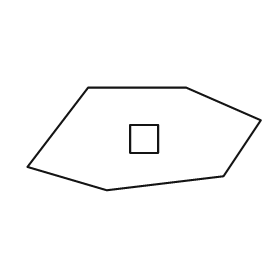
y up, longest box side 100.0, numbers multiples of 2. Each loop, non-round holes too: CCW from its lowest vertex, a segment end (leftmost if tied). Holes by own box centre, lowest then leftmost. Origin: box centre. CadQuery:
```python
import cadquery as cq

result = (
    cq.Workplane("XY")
    .moveTo(-16.0, -22.0)
    .lineTo(34.0, -16.0)
    .lineTo(50.0, 8.0)
    .lineTo(18.0, 22.0)
    .lineTo(-24.0, 22.0)
    .lineTo(-50.0, -12.0)
    .close()
    .moveTo(-6.0, -6.0)
    .lineTo(6.0, -6.0)
    .lineTo(6.0, 6.0)
    .lineTo(-6.0, 6.0)
    .close()
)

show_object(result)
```